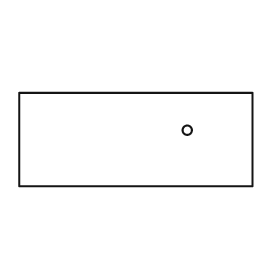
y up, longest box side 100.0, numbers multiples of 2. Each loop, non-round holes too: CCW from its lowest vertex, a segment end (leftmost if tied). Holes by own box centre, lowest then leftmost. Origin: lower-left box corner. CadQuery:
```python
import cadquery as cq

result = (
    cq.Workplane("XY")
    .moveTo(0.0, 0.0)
    .lineTo(100.0, 0.0)
    .lineTo(100.0, 40.0)
    .lineTo(0.0, 40.0)
    .close()
    .moveTo(72.0, 24.0)
    .circle(2.0)
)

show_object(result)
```